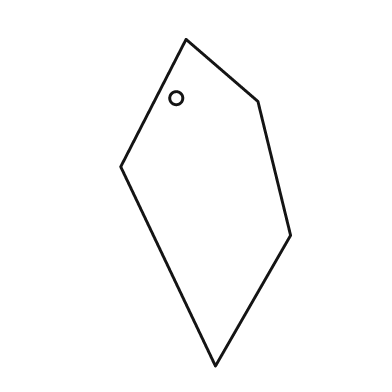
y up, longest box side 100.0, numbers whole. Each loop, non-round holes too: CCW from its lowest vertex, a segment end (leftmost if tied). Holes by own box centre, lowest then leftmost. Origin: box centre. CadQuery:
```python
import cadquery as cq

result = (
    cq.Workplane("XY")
    .moveTo(3.0, -50.0)
    .lineTo(26.0, -10.0)
    .lineTo(16.0, 31.0)
    .lineTo(-6.0, 50.0)
    .lineTo(-26.0, 11.0)
    .close()
    .moveTo(-9.0, 32.0)
    .circle(2.0)
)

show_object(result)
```